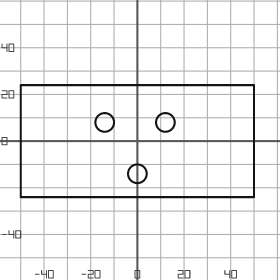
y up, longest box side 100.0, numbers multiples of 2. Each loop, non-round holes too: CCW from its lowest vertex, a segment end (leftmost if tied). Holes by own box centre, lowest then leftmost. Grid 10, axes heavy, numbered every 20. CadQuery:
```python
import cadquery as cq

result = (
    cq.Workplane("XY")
    .moveTo(-50.0, -24.0)
    .lineTo(50.0, -24.0)
    .lineTo(50.0, 24.0)
    .lineTo(-50.0, 24.0)
    .close()
    .moveTo(0.0, -14.0)
    .circle(4.0)
    .moveTo(-14.0, 8.0)
    .circle(4.0)
    .moveTo(12.0, 8.0)
    .circle(4.0)
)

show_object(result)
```